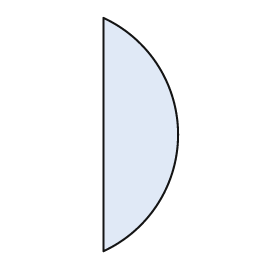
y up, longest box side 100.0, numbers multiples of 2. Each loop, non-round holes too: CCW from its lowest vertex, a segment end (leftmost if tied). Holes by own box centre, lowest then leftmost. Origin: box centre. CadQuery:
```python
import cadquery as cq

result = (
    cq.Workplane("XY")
    .moveTo(-16.0, -50.0)
    .threePointArc((16.0, 0.0), (-16.0, 50.0))
    .close()
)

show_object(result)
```